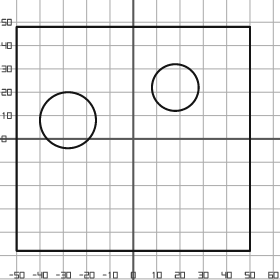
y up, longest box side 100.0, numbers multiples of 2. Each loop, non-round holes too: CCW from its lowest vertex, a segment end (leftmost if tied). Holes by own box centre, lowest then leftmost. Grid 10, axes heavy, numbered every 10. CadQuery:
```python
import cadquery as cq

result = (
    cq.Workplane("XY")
    .moveTo(-50.0, -48.0)
    .lineTo(50.0, -48.0)
    .lineTo(50.0, 48.0)
    .lineTo(-50.0, 48.0)
    .close()
    .moveTo(-28.0, 8.0)
    .circle(12.0)
    .moveTo(18.0, 22.0)
    .circle(10.0)
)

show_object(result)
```